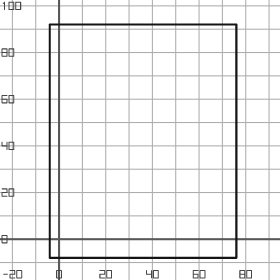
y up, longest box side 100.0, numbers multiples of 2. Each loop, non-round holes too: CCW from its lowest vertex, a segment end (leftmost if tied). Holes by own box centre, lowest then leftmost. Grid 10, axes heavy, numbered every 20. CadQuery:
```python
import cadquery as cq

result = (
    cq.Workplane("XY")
    .moveTo(-4.0, -8.0)
    .lineTo(76.0, -8.0)
    .lineTo(76.0, 92.0)
    .lineTo(-4.0, 92.0)
    .close()
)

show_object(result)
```